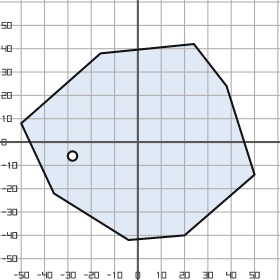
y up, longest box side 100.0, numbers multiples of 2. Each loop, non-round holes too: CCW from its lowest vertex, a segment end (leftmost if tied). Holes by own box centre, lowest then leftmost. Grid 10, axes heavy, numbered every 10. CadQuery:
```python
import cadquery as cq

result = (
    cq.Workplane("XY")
    .moveTo(-4.0, -42.0)
    .lineTo(20.0, -40.0)
    .lineTo(50.0, -14.0)
    .lineTo(38.0, 24.0)
    .lineTo(24.0, 42.0)
    .lineTo(-16.0, 38.0)
    .lineTo(-50.0, 8.0)
    .lineTo(-36.0, -22.0)
    .close()
    .moveTo(-28.0, -6.0)
    .circle(2.0)
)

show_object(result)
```